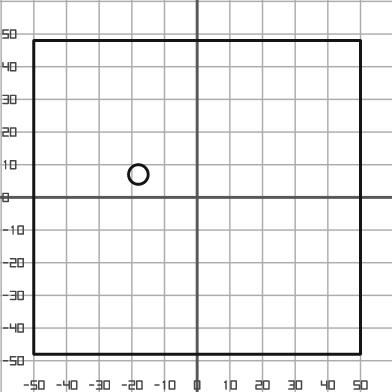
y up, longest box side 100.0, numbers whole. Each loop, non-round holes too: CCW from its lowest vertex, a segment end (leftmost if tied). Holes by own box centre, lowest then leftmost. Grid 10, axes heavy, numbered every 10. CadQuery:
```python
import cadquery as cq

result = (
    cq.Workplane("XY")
    .moveTo(-50.0, -48.0)
    .lineTo(50.0, -48.0)
    .lineTo(50.0, 48.0)
    .lineTo(-50.0, 48.0)
    .close()
    .moveTo(-18.0, 7.0)
    .circle(3.0)
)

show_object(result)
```